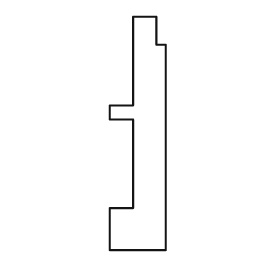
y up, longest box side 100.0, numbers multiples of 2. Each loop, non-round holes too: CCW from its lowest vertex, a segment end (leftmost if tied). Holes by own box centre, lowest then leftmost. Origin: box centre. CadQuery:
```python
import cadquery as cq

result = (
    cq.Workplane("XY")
    .moveTo(-12.0, -50.0)
    .lineTo(12.0, -50.0)
    .lineTo(12.0, 38.0)
    .lineTo(8.0, 38.0)
    .lineTo(8.0, 50.0)
    .lineTo(-2.0, 50.0)
    .lineTo(-2.0, 12.0)
    .lineTo(-12.0, 12.0)
    .lineTo(-12.0, 6.0)
    .lineTo(-2.0, 6.0)
    .lineTo(-2.0, -32.0)
    .lineTo(-12.0, -32.0)
    .close()
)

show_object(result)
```